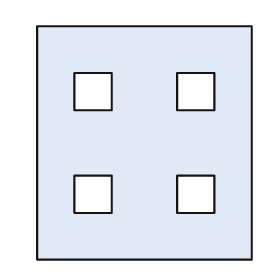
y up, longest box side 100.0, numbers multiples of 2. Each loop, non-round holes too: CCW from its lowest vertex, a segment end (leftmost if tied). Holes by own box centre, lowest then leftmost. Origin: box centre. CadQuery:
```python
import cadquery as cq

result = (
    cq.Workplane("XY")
    .moveTo(-46.0, -50.0)
    .lineTo(46.0, -50.0)
    .lineTo(46.0, 50.0)
    .lineTo(-46.0, 50.0)
    .close()
    .moveTo(-30.0, -30.0)
    .lineTo(-14.0, -30.0)
    .lineTo(-14.0, -14.0)
    .lineTo(-30.0, -14.0)
    .close()
    .moveTo(14.0, -30.0)
    .lineTo(30.0, -30.0)
    .lineTo(30.0, -14.0)
    .lineTo(14.0, -14.0)
    .close()
    .moveTo(-30.0, 14.0)
    .lineTo(-14.0, 14.0)
    .lineTo(-14.0, 30.0)
    .lineTo(-30.0, 30.0)
    .close()
    .moveTo(14.0, 14.0)
    .lineTo(30.0, 14.0)
    .lineTo(30.0, 30.0)
    .lineTo(14.0, 30.0)
    .close()
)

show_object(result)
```